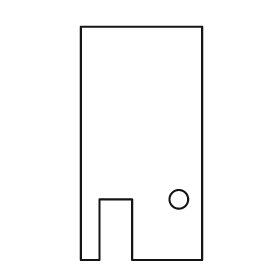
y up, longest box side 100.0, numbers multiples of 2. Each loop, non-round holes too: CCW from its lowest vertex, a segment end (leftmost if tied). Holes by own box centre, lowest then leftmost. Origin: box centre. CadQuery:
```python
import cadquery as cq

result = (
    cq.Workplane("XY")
    .moveTo(-26.0, -50.0)
    .lineTo(-18.0, -50.0)
    .lineTo(-18.0, -24.0)
    .lineTo(-4.0, -24.0)
    .lineTo(-4.0, -50.0)
    .lineTo(26.0, -50.0)
    .lineTo(26.0, 50.0)
    .lineTo(-26.0, 50.0)
    .close()
    .moveTo(16.0, -24.0)
    .circle(4.0)
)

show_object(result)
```